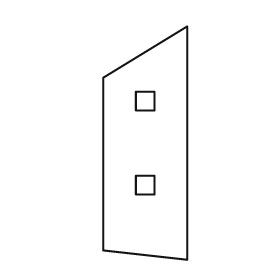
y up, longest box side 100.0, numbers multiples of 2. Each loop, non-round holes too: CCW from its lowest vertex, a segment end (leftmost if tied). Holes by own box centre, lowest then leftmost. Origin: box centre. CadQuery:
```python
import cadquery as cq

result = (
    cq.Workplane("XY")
    .moveTo(18.0, -50.0)
    .lineTo(18.0, 50.0)
    .lineTo(-18.0, 28.0)
    .lineTo(-18.0, -46.0)
    .close()
    .moveTo(-4.0, -22.0)
    .lineTo(4.0, -22.0)
    .lineTo(4.0, -14.0)
    .lineTo(-4.0, -14.0)
    .close()
    .moveTo(-4.0, 14.0)
    .lineTo(4.0, 14.0)
    .lineTo(4.0, 22.0)
    .lineTo(-4.0, 22.0)
    .close()
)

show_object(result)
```